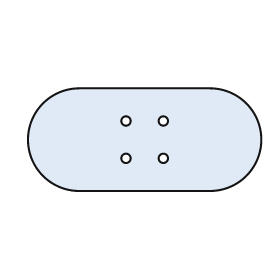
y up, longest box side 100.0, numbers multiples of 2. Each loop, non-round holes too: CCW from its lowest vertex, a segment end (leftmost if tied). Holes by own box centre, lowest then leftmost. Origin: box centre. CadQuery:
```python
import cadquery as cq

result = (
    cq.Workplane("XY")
    .moveTo(-28.0, -22.0)
    .lineTo(28.0, -22.0)
    .threePointArc((50.0, 0.0), (28.0, 22.0))
    .lineTo(-28.0, 22.0)
    .threePointArc((-50.0, 0.0), (-28.0, -22.0))
    .close()
    .moveTo(-8.0, -8.0)
    .circle(2.0)
    .moveTo(8.0, -8.0)
    .circle(2.0)
    .moveTo(-8.0, 8.0)
    .circle(2.0)
    .moveTo(8.0, 8.0)
    .circle(2.0)
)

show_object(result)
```